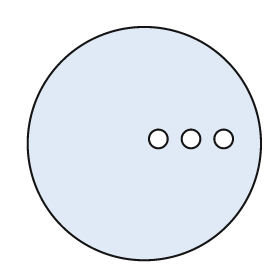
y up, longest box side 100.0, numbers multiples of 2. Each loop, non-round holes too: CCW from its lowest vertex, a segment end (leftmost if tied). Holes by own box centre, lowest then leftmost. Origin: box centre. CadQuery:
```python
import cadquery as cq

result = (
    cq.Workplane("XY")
    .moveTo(0.0, 0.0)
    .circle(50.0)
    .moveTo(6.0, 2.0)
    .circle(4.0)
    .moveTo(20.0, 2.0)
    .circle(4.0)
    .moveTo(34.0, 2.0)
    .circle(4.0)
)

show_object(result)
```